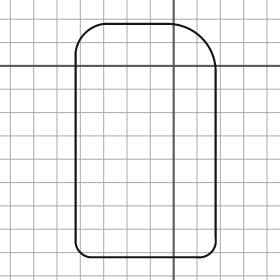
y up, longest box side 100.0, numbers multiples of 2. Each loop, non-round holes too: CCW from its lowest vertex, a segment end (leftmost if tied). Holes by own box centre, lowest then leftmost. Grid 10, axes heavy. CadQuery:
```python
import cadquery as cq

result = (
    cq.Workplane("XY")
    .moveTo(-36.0, -82.0)
    .lineTo(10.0, -82.0)
    .threePointArc((16.0, -80.0), (18.0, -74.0))
    .lineTo(18.0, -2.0)
    .threePointArc((12.0, 12.0), (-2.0, 18.0))
    .lineTo(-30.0, 18.0)
    .threePointArc((-38.0, 14.0), (-42.0, 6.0))
    .lineTo(-42.0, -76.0)
    .threePointArc((-40.0, -80.0), (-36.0, -82.0))
    .close()
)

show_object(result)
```